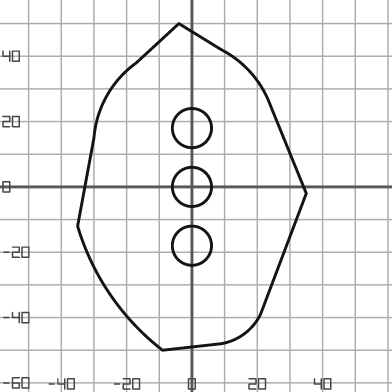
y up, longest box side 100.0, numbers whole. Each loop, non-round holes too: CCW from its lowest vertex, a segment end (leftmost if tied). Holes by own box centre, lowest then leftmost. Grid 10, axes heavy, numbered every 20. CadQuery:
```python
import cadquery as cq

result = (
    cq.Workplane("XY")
    .moveTo(-9.0, -50.0)
    .lineTo(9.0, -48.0)
    .threePointArc((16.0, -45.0), (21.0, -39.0))
    .lineTo(35.0, -2.0)
    .lineTo(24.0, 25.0)
    .threePointArc((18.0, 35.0), (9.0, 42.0))
    .lineTo(-4.0, 50.0)
    .lineTo(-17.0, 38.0)
    .threePointArc((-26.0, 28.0), (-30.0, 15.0))
    .lineTo(-35.0, -12.0)
    .threePointArc((-25.0, -33.0), (-9.0, -50.0))
    .close()
    .moveTo(0.0, -18.0)
    .circle(6.0)
    .moveTo(0.0, 0.0)
    .circle(6.0)
    .moveTo(0.0, 18.0)
    .circle(6.0)
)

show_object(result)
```